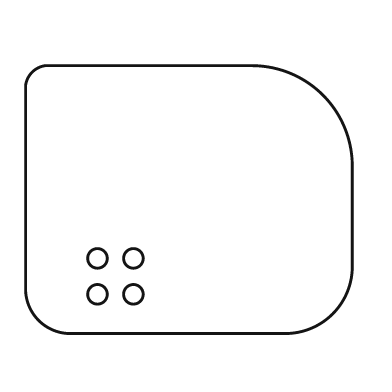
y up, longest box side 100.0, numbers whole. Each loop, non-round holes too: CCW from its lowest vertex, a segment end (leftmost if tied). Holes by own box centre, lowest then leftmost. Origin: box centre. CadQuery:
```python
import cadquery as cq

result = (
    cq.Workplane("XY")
    .moveTo(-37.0, -41.0)
    .lineTo(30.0, -41.0)
    .threePointArc((44.0, -35.0), (50.0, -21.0))
    .lineTo(50.0, 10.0)
    .threePointArc((41.0, 32.0), (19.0, 41.0))
    .lineTo(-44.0, 41.0)
    .threePointArc((-48.0, 39.0), (-50.0, 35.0))
    .lineTo(-50.0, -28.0)
    .threePointArc((-46.0, -37.0), (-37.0, -41.0))
    .close()
    .moveTo(-28.0, -29.0)
    .circle(3.0)
    .moveTo(-17.0, -29.0)
    .circle(3.0)
    .moveTo(-28.0, -18.0)
    .circle(3.0)
    .moveTo(-17.0, -18.0)
    .circle(3.0)
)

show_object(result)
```